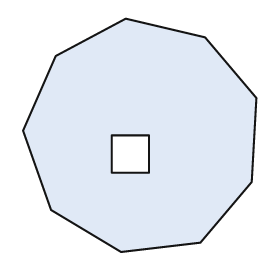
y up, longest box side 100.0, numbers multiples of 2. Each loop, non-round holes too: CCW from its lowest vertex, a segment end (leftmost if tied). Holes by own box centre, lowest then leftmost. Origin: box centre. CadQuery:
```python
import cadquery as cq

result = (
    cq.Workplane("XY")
    .moveTo(-8.0, -50.0)
    .lineTo(26.0, -46.0)
    .lineTo(48.0, -20.0)
    .lineTo(50.0, 16.0)
    .lineTo(28.0, 42.0)
    .lineTo(-6.0, 50.0)
    .lineTo(-36.0, 34.0)
    .lineTo(-50.0, 2.0)
    .lineTo(-38.0, -32.0)
    .close()
    .moveTo(-12.0, -16.0)
    .lineTo(4.0, -16.0)
    .lineTo(4.0, 0.0)
    .lineTo(-12.0, 0.0)
    .close()
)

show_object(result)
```